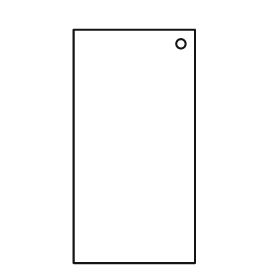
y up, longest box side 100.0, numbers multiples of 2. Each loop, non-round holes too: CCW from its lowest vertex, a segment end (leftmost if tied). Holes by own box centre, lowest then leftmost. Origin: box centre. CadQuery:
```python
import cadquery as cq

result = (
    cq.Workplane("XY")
    .moveTo(-26.0, -50.0)
    .lineTo(26.0, -50.0)
    .lineTo(26.0, 50.0)
    .lineTo(-26.0, 50.0)
    .close()
    .moveTo(20.0, 44.0)
    .circle(2.0)
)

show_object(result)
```